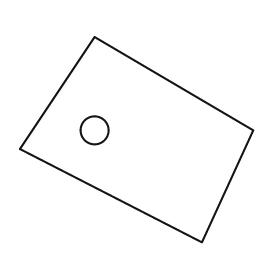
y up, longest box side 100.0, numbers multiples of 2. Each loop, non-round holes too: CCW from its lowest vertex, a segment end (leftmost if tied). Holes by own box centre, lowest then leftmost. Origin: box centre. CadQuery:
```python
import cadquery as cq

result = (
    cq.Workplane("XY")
    .moveTo(28.0, -44.0)
    .lineTo(50.0, 4.0)
    .lineTo(-18.0, 44.0)
    .lineTo(-50.0, -4.0)
    .close()
    .moveTo(-18.0, 4.0)
    .circle(6.0)
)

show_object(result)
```